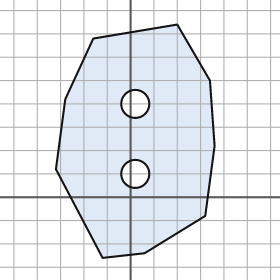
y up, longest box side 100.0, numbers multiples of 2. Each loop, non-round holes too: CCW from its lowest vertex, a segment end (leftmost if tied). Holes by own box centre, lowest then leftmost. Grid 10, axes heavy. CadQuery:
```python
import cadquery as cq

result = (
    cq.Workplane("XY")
    .moveTo(-12.0, -26.0)
    .lineTo(6.0, -24.0)
    .lineTo(32.0, -8.0)
    .lineTo(36.0, 22.0)
    .lineTo(34.0, 50.0)
    .lineTo(20.0, 74.0)
    .lineTo(-16.0, 68.0)
    .lineTo(-28.0, 42.0)
    .lineTo(-32.0, 12.0)
    .close()
    .moveTo(2.0, 10.0)
    .circle(6.0)
    .moveTo(2.0, 40.0)
    .circle(6.0)
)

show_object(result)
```